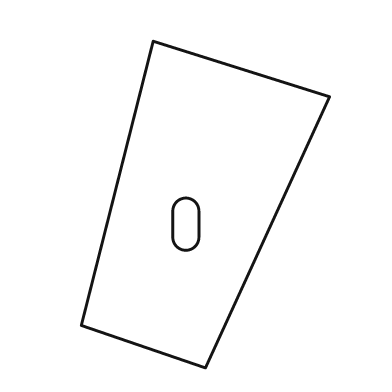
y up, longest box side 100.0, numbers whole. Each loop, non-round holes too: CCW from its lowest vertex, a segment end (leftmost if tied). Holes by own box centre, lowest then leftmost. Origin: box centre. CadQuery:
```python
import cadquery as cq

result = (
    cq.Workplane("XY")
    .moveTo(0.0, -50.0)
    .lineTo(38.0, 33.0)
    .lineTo(-16.0, 50.0)
    .lineTo(-38.0, -37.0)
    .close()
    .moveTo(-10.0, -10.0)
    .threePointArc((-6.0, -14.0), (-2.0, -10.0))
    .lineTo(-2.0, -2.0)
    .threePointArc((-6.0, 2.0), (-10.0, -2.0))
    .close()
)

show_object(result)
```